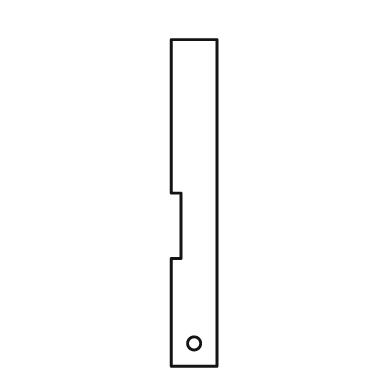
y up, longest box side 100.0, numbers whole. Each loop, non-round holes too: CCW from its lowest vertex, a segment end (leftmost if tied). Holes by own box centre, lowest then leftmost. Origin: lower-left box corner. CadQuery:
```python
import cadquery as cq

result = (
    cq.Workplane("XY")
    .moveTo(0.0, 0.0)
    .lineTo(14.0, 0.0)
    .lineTo(14.0, 100.0)
    .lineTo(0.0, 100.0)
    .lineTo(0.0, 53.0)
    .lineTo(3.0, 53.0)
    .lineTo(3.0, 33.0)
    .lineTo(0.0, 33.0)
    .close()
    .moveTo(7.0, 7.0)
    .circle(2.0)
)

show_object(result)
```